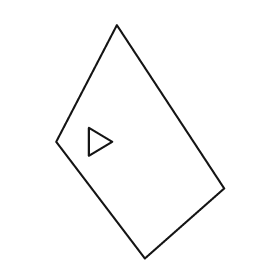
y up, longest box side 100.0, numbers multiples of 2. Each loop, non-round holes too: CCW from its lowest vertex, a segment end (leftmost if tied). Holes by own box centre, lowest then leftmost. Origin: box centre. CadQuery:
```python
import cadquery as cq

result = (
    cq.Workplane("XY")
    .moveTo(2.0, -50.0)
    .lineTo(36.0, -20.0)
    .lineTo(-10.0, 50.0)
    .lineTo(-36.0, 0.0)
    .close()
    .moveTo(-22.0, -6.0)
    .lineTo(-12.0, 0.0)
    .lineTo(-22.0, 6.0)
    .close()
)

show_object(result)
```